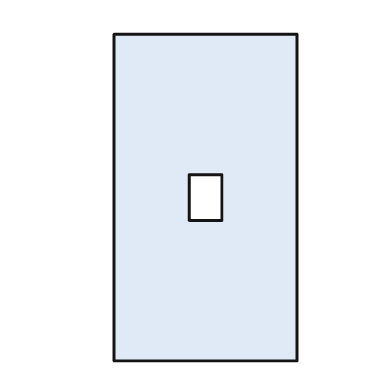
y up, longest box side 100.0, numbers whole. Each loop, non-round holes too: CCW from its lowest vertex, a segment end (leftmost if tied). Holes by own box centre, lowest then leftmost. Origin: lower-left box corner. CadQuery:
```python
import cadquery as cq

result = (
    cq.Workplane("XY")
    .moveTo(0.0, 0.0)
    .lineTo(56.0, 0.0)
    .lineTo(56.0, 100.0)
    .lineTo(0.0, 100.0)
    .close()
    .moveTo(23.0, 43.0)
    .lineTo(33.0, 43.0)
    .lineTo(33.0, 57.0)
    .lineTo(23.0, 57.0)
    .close()
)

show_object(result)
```